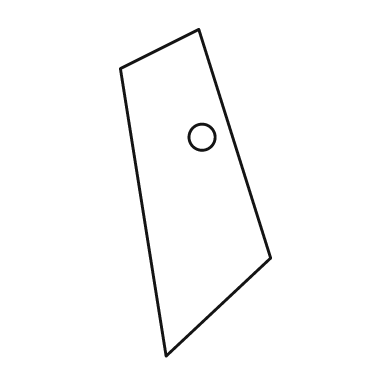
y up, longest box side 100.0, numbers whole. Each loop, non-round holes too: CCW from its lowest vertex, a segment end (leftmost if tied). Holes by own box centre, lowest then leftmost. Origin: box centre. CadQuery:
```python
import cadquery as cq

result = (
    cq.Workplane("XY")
    .moveTo(-9.0, -50.0)
    .lineTo(23.0, -20.0)
    .lineTo(1.0, 50.0)
    .lineTo(-23.0, 38.0)
    .close()
    .moveTo(2.0, 17.0)
    .circle(4.0)
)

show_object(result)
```